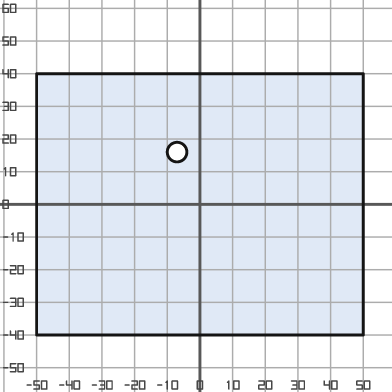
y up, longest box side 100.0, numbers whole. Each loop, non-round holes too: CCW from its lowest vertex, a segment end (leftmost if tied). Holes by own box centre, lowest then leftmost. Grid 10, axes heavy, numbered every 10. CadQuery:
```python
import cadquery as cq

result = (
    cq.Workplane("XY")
    .moveTo(-50.0, -40.0)
    .lineTo(50.0, -40.0)
    .lineTo(50.0, 40.0)
    .lineTo(-50.0, 40.0)
    .close()
    .moveTo(-7.0, 16.0)
    .circle(3.0)
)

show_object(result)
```